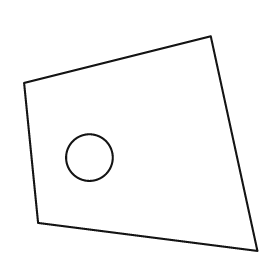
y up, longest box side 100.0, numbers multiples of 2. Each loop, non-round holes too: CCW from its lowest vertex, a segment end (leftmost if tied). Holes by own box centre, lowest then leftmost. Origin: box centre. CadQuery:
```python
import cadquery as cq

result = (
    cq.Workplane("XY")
    .moveTo(50.0, -46.0)
    .lineTo(30.0, 46.0)
    .lineTo(-50.0, 26.0)
    .lineTo(-44.0, -34.0)
    .close()
    .moveTo(-22.0, -6.0)
    .circle(10.0)
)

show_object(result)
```